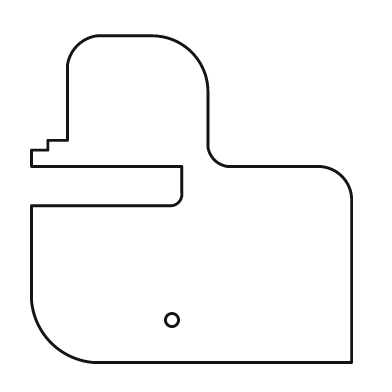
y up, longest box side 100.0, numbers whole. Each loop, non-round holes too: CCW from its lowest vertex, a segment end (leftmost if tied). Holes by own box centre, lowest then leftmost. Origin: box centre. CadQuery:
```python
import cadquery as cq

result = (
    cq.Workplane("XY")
    .moveTo(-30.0, -50.0)
    .lineTo(49.0, -50.0)
    .lineTo(49.0, 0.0)
    .threePointArc((46.0, 7.0), (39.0, 10.0))
    .lineTo(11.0, 10.0)
    .threePointArc((7.0, 12.0), (5.0, 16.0))
    .lineTo(5.0, 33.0)
    .threePointArc((0.0, 45.0), (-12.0, 50.0))
    .lineTo(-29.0, 50.0)
    .threePointArc((-35.0, 47.0), (-38.0, 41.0))
    .lineTo(-38.0, 18.0)
    .lineTo(-44.0, 18.0)
    .lineTo(-44.0, 15.0)
    .lineTo(-49.0, 15.0)
    .lineTo(-49.0, 10.0)
    .lineTo(-3.0, 10.0)
    .lineTo(-3.0, 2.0)
    .threePointArc((-4.0, -1.0), (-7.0, -2.0))
    .lineTo(-49.0, -2.0)
    .lineTo(-49.0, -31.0)
    .threePointArc((-43.0, -44.0), (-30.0, -50.0))
    .close()
    .moveTo(-6.0, -37.0)
    .circle(2.0)
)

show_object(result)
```